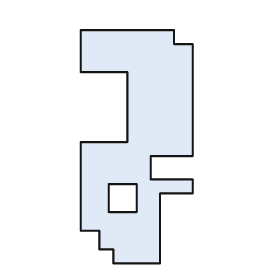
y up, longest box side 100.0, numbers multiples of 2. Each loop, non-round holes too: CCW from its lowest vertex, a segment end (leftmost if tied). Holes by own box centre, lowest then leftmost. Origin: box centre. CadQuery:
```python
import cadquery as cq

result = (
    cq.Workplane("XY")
    .moveTo(-10.0, -50.0)
    .lineTo(10.0, -50.0)
    .lineTo(10.0, -20.0)
    .lineTo(24.0, -20.0)
    .lineTo(24.0, -14.0)
    .lineTo(6.0, -14.0)
    .lineTo(6.0, -4.0)
    .lineTo(24.0, -4.0)
    .lineTo(24.0, 44.0)
    .lineTo(16.0, 44.0)
    .lineTo(16.0, 50.0)
    .lineTo(-24.0, 50.0)
    .lineTo(-24.0, 32.0)
    .lineTo(-4.0, 32.0)
    .lineTo(-4.0, 2.0)
    .lineTo(-24.0, 2.0)
    .lineTo(-24.0, -36.0)
    .lineTo(-16.0, -36.0)
    .lineTo(-16.0, -44.0)
    .lineTo(-10.0, -44.0)
    .close()
    .moveTo(-12.0, -28.0)
    .lineTo(0.0, -28.0)
    .lineTo(0.0, -16.0)
    .lineTo(-12.0, -16.0)
    .close()
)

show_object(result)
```